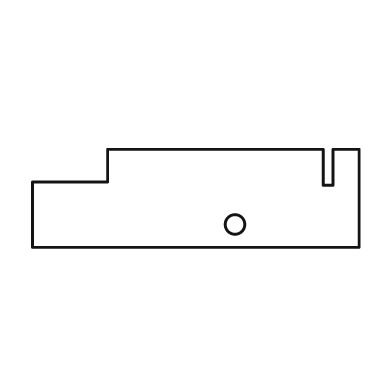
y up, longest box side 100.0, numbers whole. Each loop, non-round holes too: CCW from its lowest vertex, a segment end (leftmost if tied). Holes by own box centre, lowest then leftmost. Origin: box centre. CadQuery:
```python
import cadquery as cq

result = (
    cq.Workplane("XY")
    .moveTo(-50.0, -15.0)
    .lineTo(50.0, -15.0)
    .lineTo(50.0, 15.0)
    .lineTo(42.0, 15.0)
    .lineTo(42.0, 4.0)
    .lineTo(39.0, 4.0)
    .lineTo(39.0, 15.0)
    .lineTo(-27.0, 15.0)
    .lineTo(-27.0, 5.0)
    .lineTo(-50.0, 5.0)
    .close()
    .moveTo(12.0, -8.0)
    .circle(3.0)
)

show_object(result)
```